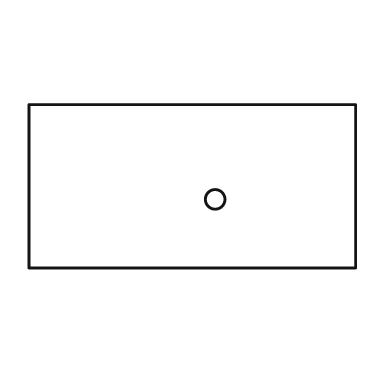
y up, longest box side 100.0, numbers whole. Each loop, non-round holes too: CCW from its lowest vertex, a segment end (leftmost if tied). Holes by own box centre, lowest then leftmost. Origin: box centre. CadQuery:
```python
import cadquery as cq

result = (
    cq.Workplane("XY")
    .moveTo(-50.0, -25.0)
    .lineTo(50.0, -25.0)
    .lineTo(50.0, 25.0)
    .lineTo(-50.0, 25.0)
    .close()
    .moveTo(7.0, -4.0)
    .circle(3.0)
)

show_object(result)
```